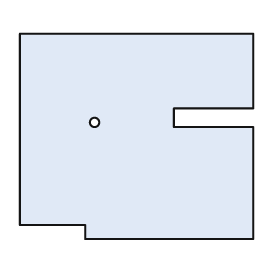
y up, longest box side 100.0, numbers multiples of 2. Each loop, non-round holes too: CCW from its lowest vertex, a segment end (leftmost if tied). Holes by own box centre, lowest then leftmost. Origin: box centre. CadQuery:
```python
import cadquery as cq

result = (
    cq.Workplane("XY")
    .moveTo(-22.0, -44.0)
    .lineTo(50.0, -44.0)
    .lineTo(50.0, 4.0)
    .lineTo(16.0, 4.0)
    .lineTo(16.0, 12.0)
    .lineTo(50.0, 12.0)
    .lineTo(50.0, 44.0)
    .lineTo(-50.0, 44.0)
    .lineTo(-50.0, -38.0)
    .lineTo(-22.0, -38.0)
    .close()
    .moveTo(-18.0, 6.0)
    .circle(2.0)
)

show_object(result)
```